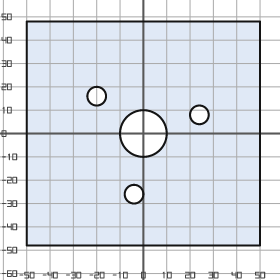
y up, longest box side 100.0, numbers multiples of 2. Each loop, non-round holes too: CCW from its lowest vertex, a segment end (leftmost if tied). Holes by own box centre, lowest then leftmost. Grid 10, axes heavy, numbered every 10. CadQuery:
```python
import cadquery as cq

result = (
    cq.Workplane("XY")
    .moveTo(-50.0, -48.0)
    .lineTo(50.0, -48.0)
    .lineTo(50.0, 48.0)
    .lineTo(-50.0, 48.0)
    .close()
    .moveTo(-4.0, -26.0)
    .circle(4.0)
    .moveTo(0.0, 0.0)
    .circle(10.0)
    .moveTo(24.0, 8.0)
    .circle(4.0)
    .moveTo(-20.0, 16.0)
    .circle(4.0)
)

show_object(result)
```